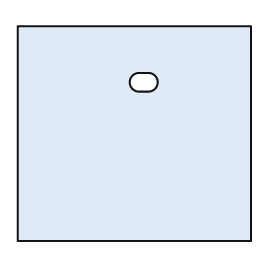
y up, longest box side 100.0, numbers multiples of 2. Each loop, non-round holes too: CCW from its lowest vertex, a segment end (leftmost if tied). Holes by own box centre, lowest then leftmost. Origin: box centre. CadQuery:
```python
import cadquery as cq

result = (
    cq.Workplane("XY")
    .moveTo(-50.0, -46.0)
    .lineTo(50.0, -46.0)
    .lineTo(50.0, 46.0)
    .lineTo(-50.0, 46.0)
    .close()
    .moveTo(2.0, 18.0)
    .lineTo(6.0, 18.0)
    .threePointArc((10.0, 22.0), (6.0, 26.0))
    .lineTo(2.0, 26.0)
    .threePointArc((-2.0, 22.0), (2.0, 18.0))
    .close()
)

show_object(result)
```